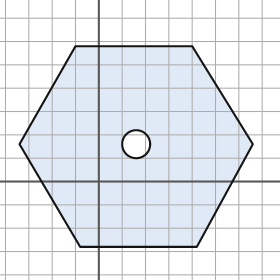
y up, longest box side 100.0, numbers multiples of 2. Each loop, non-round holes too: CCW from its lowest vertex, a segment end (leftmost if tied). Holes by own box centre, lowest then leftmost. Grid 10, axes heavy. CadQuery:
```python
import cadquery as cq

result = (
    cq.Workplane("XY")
    .moveTo(-8.0, -28.0)
    .lineTo(42.0, -28.0)
    .lineTo(66.0, 16.0)
    .lineTo(40.0, 58.0)
    .lineTo(-10.0, 58.0)
    .lineTo(-34.0, 16.0)
    .close()
    .moveTo(16.0, 16.0)
    .circle(6.0)
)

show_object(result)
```